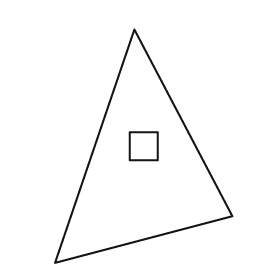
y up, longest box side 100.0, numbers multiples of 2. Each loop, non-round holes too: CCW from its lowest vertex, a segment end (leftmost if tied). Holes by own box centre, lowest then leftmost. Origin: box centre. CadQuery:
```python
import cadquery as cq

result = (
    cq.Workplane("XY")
    .moveTo(-38.0, -50.0)
    .lineTo(38.0, -30.0)
    .lineTo(-4.0, 50.0)
    .close()
    .moveTo(-6.0, -6.0)
    .lineTo(6.0, -6.0)
    .lineTo(6.0, 6.0)
    .lineTo(-6.0, 6.0)
    .close()
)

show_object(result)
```